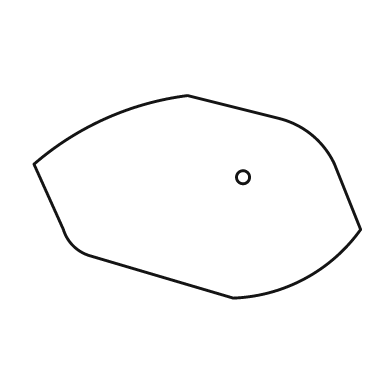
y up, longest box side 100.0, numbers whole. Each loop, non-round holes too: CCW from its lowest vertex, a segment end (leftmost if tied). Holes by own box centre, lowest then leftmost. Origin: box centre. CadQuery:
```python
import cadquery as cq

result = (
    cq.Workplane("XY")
    .moveTo(11.0, -31.0)
    .threePointArc((33.0, -25.0), (50.0, -10.0))
    .lineTo(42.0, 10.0)
    .threePointArc((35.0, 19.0), (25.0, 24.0))
    .lineTo(-3.0, 31.0)
    .threePointArc((-28.0, 24.0), (-50.0, 10.0))
    .lineTo(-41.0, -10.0)
    .threePointArc((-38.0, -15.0), (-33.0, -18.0))
    .close()
    .moveTo(14.0, 6.0)
    .circle(2.0)
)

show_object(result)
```